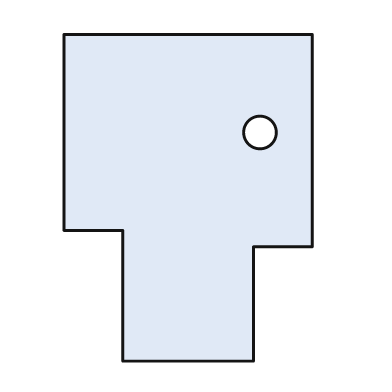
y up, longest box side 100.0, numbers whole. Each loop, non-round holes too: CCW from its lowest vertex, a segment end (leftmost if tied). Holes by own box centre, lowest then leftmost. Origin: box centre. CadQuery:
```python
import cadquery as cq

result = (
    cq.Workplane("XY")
    .moveTo(-20.0, -50.0)
    .lineTo(20.0, -50.0)
    .lineTo(20.0, -15.0)
    .lineTo(38.0, -15.0)
    .lineTo(38.0, 50.0)
    .lineTo(-38.0, 50.0)
    .lineTo(-38.0, -10.0)
    .lineTo(-20.0, -10.0)
    .close()
    .moveTo(22.0, 20.0)
    .circle(5.0)
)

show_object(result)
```